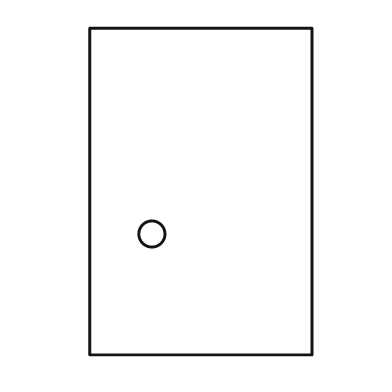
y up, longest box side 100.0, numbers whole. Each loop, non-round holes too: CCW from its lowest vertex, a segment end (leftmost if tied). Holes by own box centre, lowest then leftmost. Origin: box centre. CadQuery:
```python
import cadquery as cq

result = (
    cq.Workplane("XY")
    .moveTo(-34.0, -50.0)
    .lineTo(34.0, -50.0)
    .lineTo(34.0, 50.0)
    .lineTo(-34.0, 50.0)
    .close()
    .moveTo(-15.0, -13.0)
    .circle(4.0)
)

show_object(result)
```